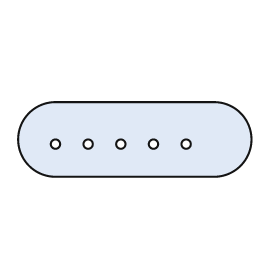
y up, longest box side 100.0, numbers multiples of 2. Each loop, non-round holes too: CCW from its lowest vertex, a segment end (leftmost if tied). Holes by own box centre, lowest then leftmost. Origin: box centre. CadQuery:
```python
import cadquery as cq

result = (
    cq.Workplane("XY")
    .moveTo(-34.0, -16.0)
    .lineTo(34.0, -16.0)
    .threePointArc((50.0, 0.0), (34.0, 16.0))
    .lineTo(-34.0, 16.0)
    .threePointArc((-50.0, 0.0), (-34.0, -16.0))
    .close()
    .moveTo(-34.0, -2.0)
    .circle(2.0)
    .moveTo(-20.0, -2.0)
    .circle(2.0)
    .moveTo(-6.0, -2.0)
    .circle(2.0)
    .moveTo(8.0, -2.0)
    .circle(2.0)
    .moveTo(22.0, -2.0)
    .circle(2.0)
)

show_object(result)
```